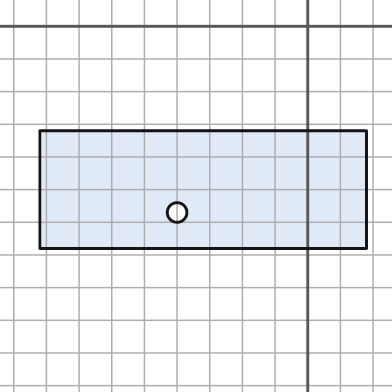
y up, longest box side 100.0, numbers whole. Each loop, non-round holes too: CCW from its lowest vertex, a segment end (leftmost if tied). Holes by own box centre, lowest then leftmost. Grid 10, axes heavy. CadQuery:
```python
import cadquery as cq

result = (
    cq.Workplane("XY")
    .moveTo(-82.0, -68.0)
    .lineTo(18.0, -68.0)
    .lineTo(18.0, -32.0)
    .lineTo(-82.0, -32.0)
    .close()
    .moveTo(-40.0, -57.0)
    .circle(3.0)
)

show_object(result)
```